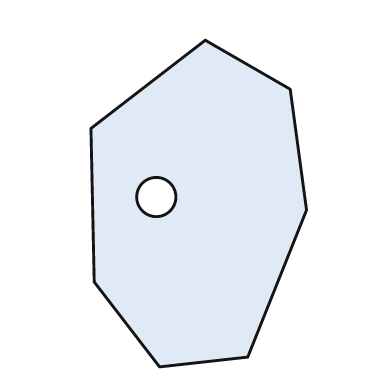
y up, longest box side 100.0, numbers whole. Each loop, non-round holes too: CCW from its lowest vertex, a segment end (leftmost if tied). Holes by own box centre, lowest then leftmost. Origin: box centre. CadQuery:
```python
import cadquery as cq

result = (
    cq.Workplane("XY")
    .moveTo(-12.0, -50.0)
    .lineTo(15.0, -47.0)
    .lineTo(33.0, -2.0)
    .lineTo(28.0, 35.0)
    .lineTo(2.0, 50.0)
    .lineTo(-33.0, 23.0)
    .lineTo(-32.0, -24.0)
    .close()
    .moveTo(-13.0, 2.0)
    .circle(6.0)
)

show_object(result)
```